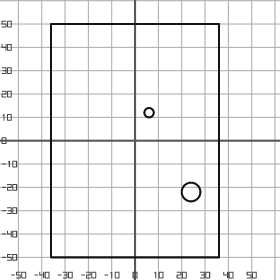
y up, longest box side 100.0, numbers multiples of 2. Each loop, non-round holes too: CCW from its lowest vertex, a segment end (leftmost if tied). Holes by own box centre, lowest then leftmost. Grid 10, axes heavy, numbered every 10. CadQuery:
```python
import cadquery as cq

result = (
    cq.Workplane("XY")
    .moveTo(-36.0, -50.0)
    .lineTo(36.0, -50.0)
    .lineTo(36.0, 50.0)
    .lineTo(-36.0, 50.0)
    .close()
    .moveTo(24.0, -22.0)
    .circle(4.0)
    .moveTo(6.0, 12.0)
    .circle(2.0)
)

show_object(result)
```